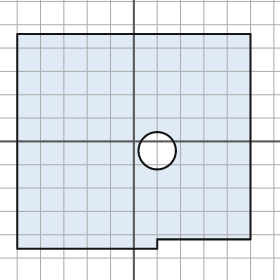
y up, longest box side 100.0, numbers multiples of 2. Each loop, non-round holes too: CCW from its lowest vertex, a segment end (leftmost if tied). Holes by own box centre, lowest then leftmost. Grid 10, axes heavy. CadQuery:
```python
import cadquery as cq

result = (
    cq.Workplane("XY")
    .moveTo(-50.0, -46.0)
    .lineTo(10.0, -46.0)
    .lineTo(10.0, -42.0)
    .lineTo(50.0, -42.0)
    .lineTo(50.0, 46.0)
    .lineTo(-50.0, 46.0)
    .close()
    .moveTo(10.0, -4.0)
    .circle(8.0)
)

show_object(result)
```